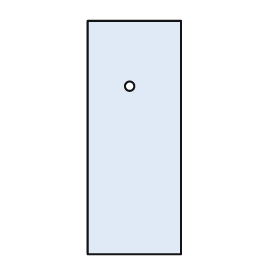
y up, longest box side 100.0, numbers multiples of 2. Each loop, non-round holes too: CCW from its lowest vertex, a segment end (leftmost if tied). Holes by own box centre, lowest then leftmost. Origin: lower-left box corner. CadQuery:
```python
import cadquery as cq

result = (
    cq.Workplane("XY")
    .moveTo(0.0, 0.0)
    .lineTo(40.0, 0.0)
    .lineTo(40.0, 100.0)
    .lineTo(0.0, 100.0)
    .close()
    .moveTo(18.0, 72.0)
    .circle(2.0)
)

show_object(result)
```